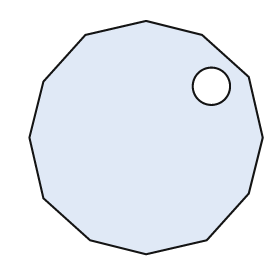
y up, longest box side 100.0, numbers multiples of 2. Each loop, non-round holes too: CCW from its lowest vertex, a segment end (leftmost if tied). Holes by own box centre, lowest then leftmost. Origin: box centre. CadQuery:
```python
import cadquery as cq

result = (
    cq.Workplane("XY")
    .moveTo(0.0, -50.0)
    .lineTo(26.0, -44.0)
    .lineTo(44.0, -24.0)
    .lineTo(50.0, 0.0)
    .lineTo(44.0, 26.0)
    .lineTo(24.0, 44.0)
    .lineTo(0.0, 50.0)
    .lineTo(-26.0, 44.0)
    .lineTo(-44.0, 24.0)
    .lineTo(-50.0, 0.0)
    .lineTo(-44.0, -26.0)
    .lineTo(-24.0, -44.0)
    .close()
    .moveTo(28.0, 22.0)
    .circle(8.0)
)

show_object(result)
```